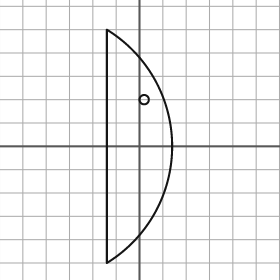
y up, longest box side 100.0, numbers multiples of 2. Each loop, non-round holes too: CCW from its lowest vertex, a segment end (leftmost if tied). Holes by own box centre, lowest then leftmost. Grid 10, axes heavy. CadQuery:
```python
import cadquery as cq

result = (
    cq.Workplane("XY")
    .moveTo(-14.0, -50.0)
    .threePointArc((14.0, 0.0), (-14.0, 50.0))
    .close()
    .moveTo(2.0, 20.0)
    .circle(2.0)
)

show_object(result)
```